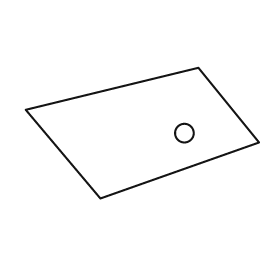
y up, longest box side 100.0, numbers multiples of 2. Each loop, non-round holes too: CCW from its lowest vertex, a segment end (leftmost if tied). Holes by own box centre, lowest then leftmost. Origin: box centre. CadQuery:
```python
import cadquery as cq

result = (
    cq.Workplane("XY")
    .moveTo(-18.0, -28.0)
    .lineTo(50.0, -4.0)
    .lineTo(24.0, 28.0)
    .lineTo(-50.0, 10.0)
    .close()
    .moveTo(18.0, 0.0)
    .circle(4.0)
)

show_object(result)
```